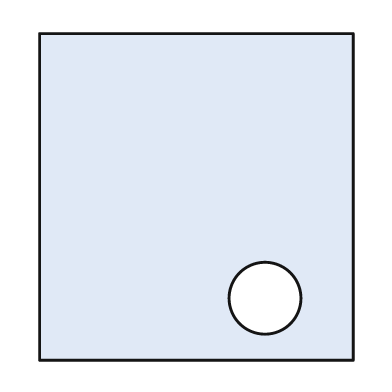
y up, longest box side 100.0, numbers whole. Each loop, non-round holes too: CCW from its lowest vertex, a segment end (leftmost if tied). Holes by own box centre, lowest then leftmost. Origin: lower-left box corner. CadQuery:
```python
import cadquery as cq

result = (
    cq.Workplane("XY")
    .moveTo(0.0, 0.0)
    .lineTo(96.0, 0.0)
    .lineTo(96.0, 100.0)
    .lineTo(0.0, 100.0)
    .close()
    .moveTo(69.0, 19.0)
    .circle(11.0)
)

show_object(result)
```